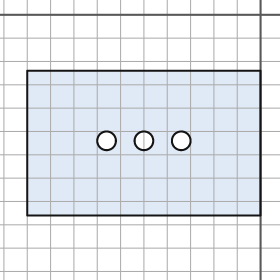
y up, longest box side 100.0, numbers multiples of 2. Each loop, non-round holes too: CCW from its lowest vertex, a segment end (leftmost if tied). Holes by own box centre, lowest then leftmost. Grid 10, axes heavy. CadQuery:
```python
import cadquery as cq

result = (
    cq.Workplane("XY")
    .moveTo(-100.0, -86.0)
    .lineTo(0.0, -86.0)
    .lineTo(0.0, -24.0)
    .lineTo(-100.0, -24.0)
    .close()
    .moveTo(-66.0, -54.0)
    .circle(4.0)
    .moveTo(-50.0, -54.0)
    .circle(4.0)
    .moveTo(-34.0, -54.0)
    .circle(4.0)
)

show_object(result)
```